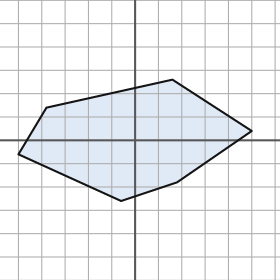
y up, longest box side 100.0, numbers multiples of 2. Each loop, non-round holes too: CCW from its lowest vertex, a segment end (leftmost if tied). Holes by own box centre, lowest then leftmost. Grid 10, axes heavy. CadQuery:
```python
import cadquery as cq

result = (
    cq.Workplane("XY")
    .moveTo(-6.0, -26.0)
    .lineTo(18.0, -18.0)
    .lineTo(50.0, 4.0)
    .lineTo(16.0, 26.0)
    .lineTo(-38.0, 14.0)
    .lineTo(-50.0, -6.0)
    .close()
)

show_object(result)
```